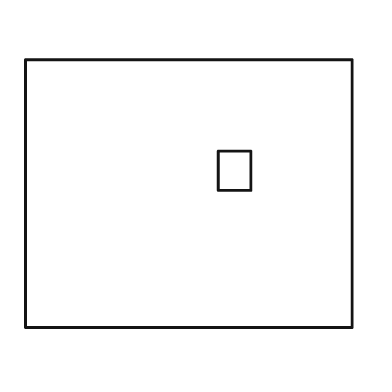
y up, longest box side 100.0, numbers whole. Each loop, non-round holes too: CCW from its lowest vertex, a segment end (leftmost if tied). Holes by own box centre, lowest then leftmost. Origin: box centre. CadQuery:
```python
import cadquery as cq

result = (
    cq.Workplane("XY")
    .moveTo(-50.0, -41.0)
    .lineTo(50.0, -41.0)
    .lineTo(50.0, 41.0)
    .lineTo(-50.0, 41.0)
    .close()
    .moveTo(9.0, 1.0)
    .lineTo(19.0, 1.0)
    .lineTo(19.0, 13.0)
    .lineTo(9.0, 13.0)
    .close()
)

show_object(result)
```